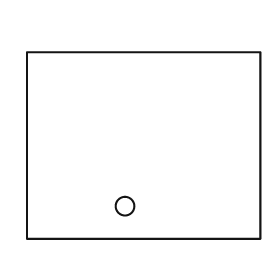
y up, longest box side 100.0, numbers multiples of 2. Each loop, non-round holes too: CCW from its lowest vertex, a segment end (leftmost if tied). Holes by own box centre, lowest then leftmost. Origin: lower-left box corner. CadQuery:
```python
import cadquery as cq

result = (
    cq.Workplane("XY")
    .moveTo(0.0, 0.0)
    .lineTo(100.0, 0.0)
    .lineTo(100.0, 80.0)
    .lineTo(0.0, 80.0)
    .close()
    .moveTo(42.0, 14.0)
    .circle(4.0)
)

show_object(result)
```